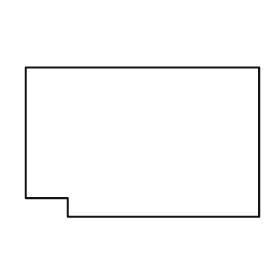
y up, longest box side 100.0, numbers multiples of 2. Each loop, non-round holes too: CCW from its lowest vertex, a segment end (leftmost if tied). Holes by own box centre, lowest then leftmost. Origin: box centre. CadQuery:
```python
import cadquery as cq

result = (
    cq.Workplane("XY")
    .moveTo(-32.0, -32.0)
    .lineTo(50.0, -32.0)
    .lineTo(50.0, 32.0)
    .lineTo(-50.0, 32.0)
    .lineTo(-50.0, -24.0)
    .lineTo(-32.0, -24.0)
    .close()
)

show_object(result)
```